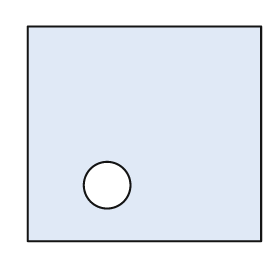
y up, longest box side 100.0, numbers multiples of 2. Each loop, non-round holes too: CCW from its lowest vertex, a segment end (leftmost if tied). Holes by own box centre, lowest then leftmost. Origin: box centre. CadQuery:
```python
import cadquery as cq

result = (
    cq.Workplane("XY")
    .moveTo(-50.0, -46.0)
    .lineTo(50.0, -46.0)
    .lineTo(50.0, 46.0)
    .lineTo(-50.0, 46.0)
    .close()
    .moveTo(-16.0, -22.0)
    .circle(10.0)
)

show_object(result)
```